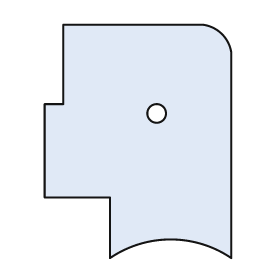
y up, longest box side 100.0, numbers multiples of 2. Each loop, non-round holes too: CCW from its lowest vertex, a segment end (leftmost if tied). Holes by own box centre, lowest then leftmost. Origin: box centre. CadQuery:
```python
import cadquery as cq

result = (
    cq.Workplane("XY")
    .moveTo(-12.0, -50.0)
    .threePointArc((14.0, -42.0), (40.0, -50.0))
    .lineTo(40.0, 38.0)
    .threePointArc((36.0, 46.0), (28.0, 50.0))
    .lineTo(-32.0, 50.0)
    .lineTo(-32.0, 16.0)
    .lineTo(-40.0, 16.0)
    .lineTo(-40.0, -24.0)
    .lineTo(-12.0, -24.0)
    .close()
    .moveTo(8.0, 12.0)
    .circle(4.0)
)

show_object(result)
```